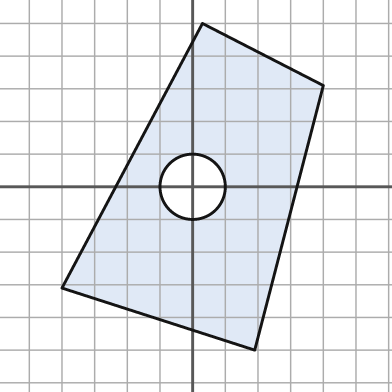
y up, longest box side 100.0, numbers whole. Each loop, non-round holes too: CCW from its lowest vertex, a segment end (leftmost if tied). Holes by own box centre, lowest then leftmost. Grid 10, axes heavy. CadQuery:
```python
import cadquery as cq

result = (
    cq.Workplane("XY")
    .moveTo(19.0, -50.0)
    .lineTo(40.0, 31.0)
    .lineTo(3.0, 50.0)
    .lineTo(-40.0, -31.0)
    .close()
    .moveTo(0.0, 0.0)
    .circle(10.0)
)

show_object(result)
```